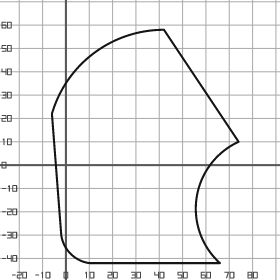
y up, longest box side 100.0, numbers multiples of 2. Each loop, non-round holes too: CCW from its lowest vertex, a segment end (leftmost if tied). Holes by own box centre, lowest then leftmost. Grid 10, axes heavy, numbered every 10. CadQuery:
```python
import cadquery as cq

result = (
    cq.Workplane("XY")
    .moveTo(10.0, -42.0)
    .lineTo(66.0, -42.0)
    .threePointArc((56.0, -14.0), (74.0, 10.0))
    .lineTo(42.0, 58.0)
    .threePointArc((12.0, 48.0), (-6.0, 22.0))
    .lineTo(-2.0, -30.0)
    .threePointArc((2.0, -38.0), (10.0, -42.0))
    .close()
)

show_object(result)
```